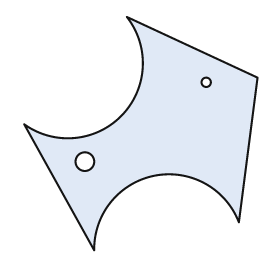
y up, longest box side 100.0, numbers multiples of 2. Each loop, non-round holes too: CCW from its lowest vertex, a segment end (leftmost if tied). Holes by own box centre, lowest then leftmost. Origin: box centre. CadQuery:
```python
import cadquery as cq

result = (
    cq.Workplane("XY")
    .moveTo(-20.0, -50.0)
    .threePointArc((6.0, -18.0), (42.0, -38.0))
    .lineTo(50.0, 24.0)
    .lineTo(-6.0, 50.0)
    .threePointArc((-8.0, 8.0), (-50.0, 4.0))
    .close()
    .moveTo(-24.0, -12.0)
    .circle(4.0)
    .moveTo(28.0, 22.0)
    .circle(2.0)
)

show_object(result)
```